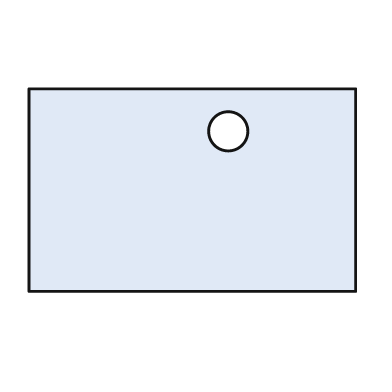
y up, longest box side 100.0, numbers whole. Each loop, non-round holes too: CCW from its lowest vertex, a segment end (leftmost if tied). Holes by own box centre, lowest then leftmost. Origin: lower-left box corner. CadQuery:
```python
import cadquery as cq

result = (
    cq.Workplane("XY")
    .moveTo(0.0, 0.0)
    .lineTo(100.0, 0.0)
    .lineTo(100.0, 62.0)
    .lineTo(0.0, 62.0)
    .close()
    .moveTo(61.0, 49.0)
    .circle(6.0)
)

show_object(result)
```